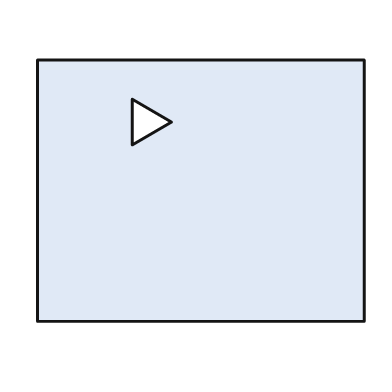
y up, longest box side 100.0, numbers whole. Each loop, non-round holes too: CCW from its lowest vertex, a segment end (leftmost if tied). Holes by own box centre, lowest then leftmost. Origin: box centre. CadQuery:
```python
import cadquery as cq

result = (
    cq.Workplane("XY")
    .moveTo(-50.0, -40.0)
    .lineTo(50.0, -40.0)
    .lineTo(50.0, 40.0)
    .lineTo(-50.0, 40.0)
    .close()
    .moveTo(-21.0, 14.0)
    .lineTo(-9.0, 21.0)
    .lineTo(-21.0, 28.0)
    .close()
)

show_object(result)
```